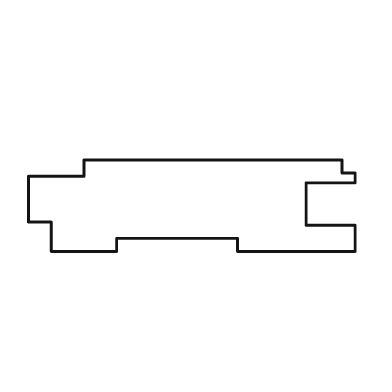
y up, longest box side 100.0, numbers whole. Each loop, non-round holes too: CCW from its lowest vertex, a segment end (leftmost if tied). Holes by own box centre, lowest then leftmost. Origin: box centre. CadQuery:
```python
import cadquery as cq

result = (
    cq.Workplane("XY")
    .moveTo(-43.0, -14.0)
    .lineTo(-23.0, -14.0)
    .lineTo(-23.0, -10.0)
    .lineTo(14.0, -10.0)
    .lineTo(14.0, -14.0)
    .lineTo(50.0, -14.0)
    .lineTo(50.0, -6.0)
    .lineTo(35.0, -6.0)
    .lineTo(35.0, 7.0)
    .lineTo(50.0, 7.0)
    .lineTo(50.0, 10.0)
    .lineTo(46.0, 10.0)
    .lineTo(46.0, 14.0)
    .lineTo(-33.0, 14.0)
    .lineTo(-33.0, 9.0)
    .lineTo(-50.0, 9.0)
    .lineTo(-50.0, -5.0)
    .lineTo(-43.0, -5.0)
    .close()
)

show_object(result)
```